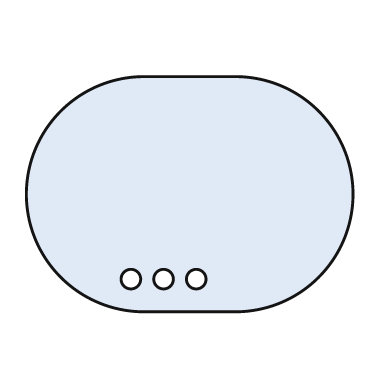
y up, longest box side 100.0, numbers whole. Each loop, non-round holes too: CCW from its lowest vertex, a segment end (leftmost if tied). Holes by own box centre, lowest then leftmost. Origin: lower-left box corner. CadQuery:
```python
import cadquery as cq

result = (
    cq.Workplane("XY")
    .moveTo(36.0, 0.0)
    .lineTo(64.0, 0.0)
    .threePointArc((100.0, 36.0), (64.0, 72.0))
    .lineTo(36.0, 72.0)
    .threePointArc((0.0, 36.0), (36.0, 0.0))
    .close()
    .moveTo(32.0, 10.0)
    .circle(3.0)
    .moveTo(42.0, 10.0)
    .circle(3.0)
    .moveTo(52.0, 10.0)
    .circle(3.0)
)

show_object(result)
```